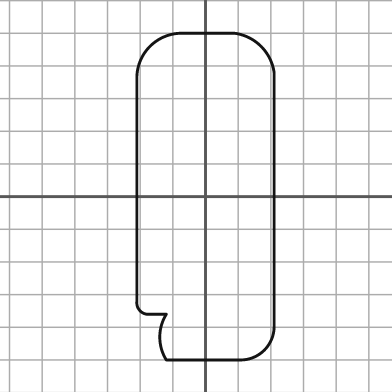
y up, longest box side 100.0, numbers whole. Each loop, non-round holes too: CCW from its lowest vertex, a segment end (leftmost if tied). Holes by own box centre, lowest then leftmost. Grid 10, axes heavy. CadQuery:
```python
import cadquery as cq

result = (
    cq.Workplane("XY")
    .moveTo(-12.0, -50.0)
    .lineTo(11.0, -50.0)
    .threePointArc((18.0, -47.0), (21.0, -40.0))
    .lineTo(21.0, 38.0)
    .threePointArc((17.0, 46.0), (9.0, 50.0))
    .lineTo(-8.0, 50.0)
    .threePointArc((-17.0, 46.0), (-21.0, 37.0))
    .lineTo(-21.0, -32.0)
    .threePointArc((-20.0, -35.0), (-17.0, -36.0))
    .lineTo(-12.0, -36.0)
    .threePointArc((-14.0, -43.0), (-12.0, -50.0))
    .close()
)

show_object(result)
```